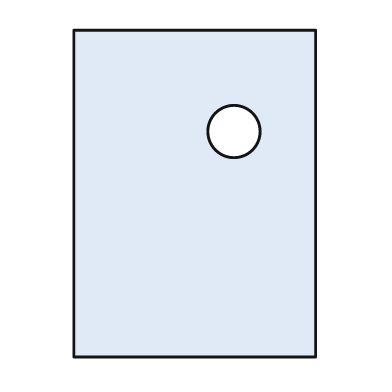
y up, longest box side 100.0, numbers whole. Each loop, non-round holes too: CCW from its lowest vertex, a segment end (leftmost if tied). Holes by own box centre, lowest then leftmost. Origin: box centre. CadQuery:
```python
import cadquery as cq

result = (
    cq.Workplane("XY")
    .moveTo(-37.0, -50.0)
    .lineTo(37.0, -50.0)
    .lineTo(37.0, 50.0)
    .lineTo(-37.0, 50.0)
    .close()
    .moveTo(12.0, 19.0)
    .circle(8.0)
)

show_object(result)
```